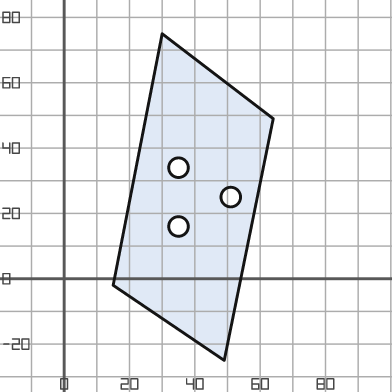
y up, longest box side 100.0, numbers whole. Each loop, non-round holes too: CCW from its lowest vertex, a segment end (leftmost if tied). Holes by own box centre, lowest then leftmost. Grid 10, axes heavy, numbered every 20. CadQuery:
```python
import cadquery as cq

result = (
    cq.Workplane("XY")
    .moveTo(49.0, -25.0)
    .lineTo(64.0, 49.0)
    .lineTo(30.0, 75.0)
    .lineTo(15.0, -2.0)
    .close()
    .moveTo(35.0, 16.0)
    .circle(3.0)
    .moveTo(51.0, 25.0)
    .circle(3.0)
    .moveTo(35.0, 34.0)
    .circle(3.0)
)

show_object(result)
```